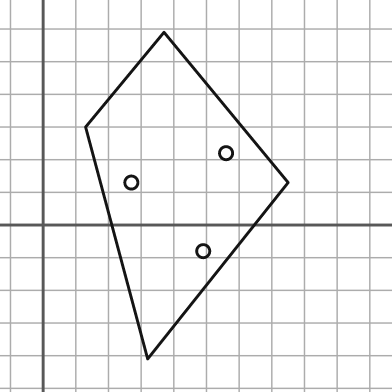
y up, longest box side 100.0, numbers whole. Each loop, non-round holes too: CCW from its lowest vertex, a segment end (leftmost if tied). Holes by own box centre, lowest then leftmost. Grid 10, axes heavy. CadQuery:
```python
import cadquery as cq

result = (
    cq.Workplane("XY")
    .moveTo(32.0, -41.0)
    .lineTo(75.0, 13.0)
    .lineTo(37.0, 59.0)
    .lineTo(13.0, 30.0)
    .close()
    .moveTo(49.0, -8.0)
    .circle(2.0)
    .moveTo(27.0, 13.0)
    .circle(2.0)
    .moveTo(56.0, 22.0)
    .circle(2.0)
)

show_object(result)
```